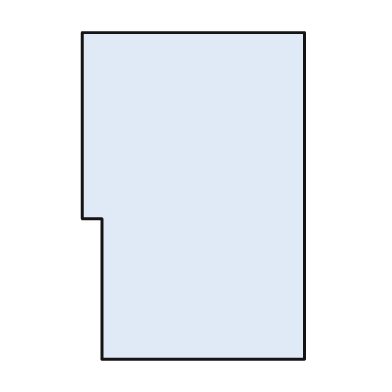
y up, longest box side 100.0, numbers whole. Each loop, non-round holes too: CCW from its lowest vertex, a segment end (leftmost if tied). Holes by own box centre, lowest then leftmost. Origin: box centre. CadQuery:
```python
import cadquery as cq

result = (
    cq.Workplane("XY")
    .moveTo(-28.0, -50.0)
    .lineTo(34.0, -50.0)
    .lineTo(34.0, 50.0)
    .lineTo(-34.0, 50.0)
    .lineTo(-34.0, -7.0)
    .lineTo(-28.0, -7.0)
    .close()
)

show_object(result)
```